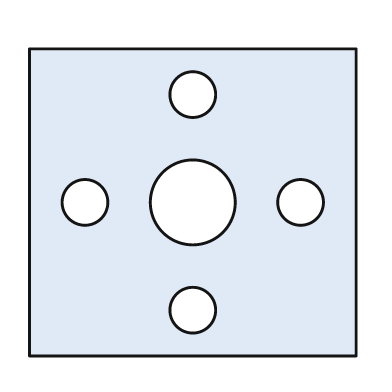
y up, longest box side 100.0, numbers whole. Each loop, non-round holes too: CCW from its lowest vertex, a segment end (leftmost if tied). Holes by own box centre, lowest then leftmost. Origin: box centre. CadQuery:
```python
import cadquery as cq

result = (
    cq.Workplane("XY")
    .moveTo(-50.0, -47.0)
    .lineTo(50.0, -47.0)
    .lineTo(50.0, 47.0)
    .lineTo(-50.0, 47.0)
    .close()
    .moveTo(0.0, -33.0)
    .circle(7.0)
    .moveTo(-33.0, 0.0)
    .circle(7.0)
    .moveTo(0.0, 0.0)
    .circle(13.0)
    .moveTo(33.0, 0.0)
    .circle(7.0)
    .moveTo(0.0, 33.0)
    .circle(7.0)
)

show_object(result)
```